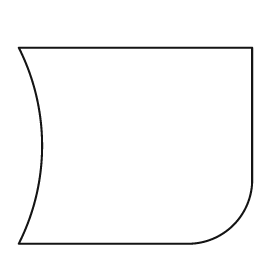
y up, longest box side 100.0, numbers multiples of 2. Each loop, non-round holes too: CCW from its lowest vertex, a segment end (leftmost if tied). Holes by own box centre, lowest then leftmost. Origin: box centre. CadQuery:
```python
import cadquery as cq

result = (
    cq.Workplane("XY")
    .moveTo(-50.0, -42.0)
    .lineTo(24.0, -42.0)
    .threePointArc((42.0, -34.0), (50.0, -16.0))
    .lineTo(50.0, 42.0)
    .lineTo(-50.0, 42.0)
    .threePointArc((-40.0, 0.0), (-50.0, -42.0))
    .close()
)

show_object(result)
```